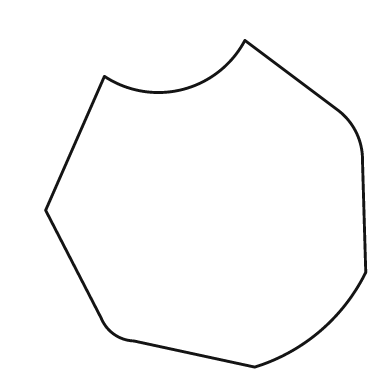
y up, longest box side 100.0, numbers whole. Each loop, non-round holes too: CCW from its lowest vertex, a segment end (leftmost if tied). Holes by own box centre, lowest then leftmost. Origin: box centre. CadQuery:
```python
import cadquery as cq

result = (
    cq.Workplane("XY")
    .moveTo(15.0, -50.0)
    .threePointArc((35.0, -39.0), (49.0, -21.0))
    .lineTo(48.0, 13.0)
    .threePointArc((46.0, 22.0), (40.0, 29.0))
    .lineTo(12.0, 50.0)
    .threePointArc((-7.0, 35.0), (-31.0, 39.0))
    .lineTo(-49.0, -2.0)
    .lineTo(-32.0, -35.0)
    .threePointArc((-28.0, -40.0), (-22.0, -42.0))
    .close()
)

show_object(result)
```